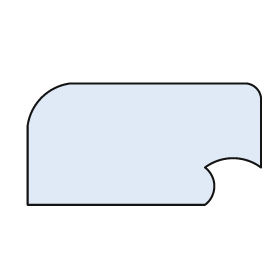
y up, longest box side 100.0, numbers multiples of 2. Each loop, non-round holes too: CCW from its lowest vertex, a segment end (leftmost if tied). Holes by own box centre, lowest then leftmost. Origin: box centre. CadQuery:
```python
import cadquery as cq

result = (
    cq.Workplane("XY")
    .moveTo(-50.0, -26.0)
    .lineTo(26.0, -26.0)
    .threePointArc((30.0, -18.0), (26.0, -10.0))
    .threePointArc((38.0, -6.0), (50.0, -10.0))
    .lineTo(50.0, 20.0)
    .threePointArc((48.0, 24.0), (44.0, 26.0))
    .lineTo(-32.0, 26.0)
    .threePointArc((-44.0, 20.0), (-50.0, 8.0))
    .close()
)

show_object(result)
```